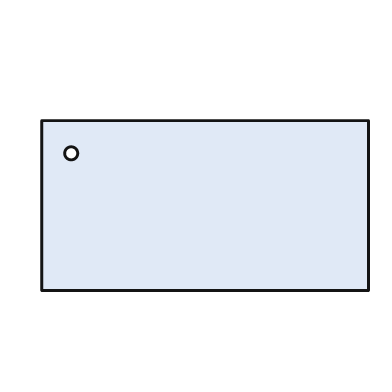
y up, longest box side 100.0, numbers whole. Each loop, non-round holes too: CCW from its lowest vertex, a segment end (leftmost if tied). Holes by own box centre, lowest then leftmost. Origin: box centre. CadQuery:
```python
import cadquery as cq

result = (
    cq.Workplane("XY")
    .moveTo(-50.0, -26.0)
    .lineTo(50.0, -26.0)
    .lineTo(50.0, 26.0)
    .lineTo(-50.0, 26.0)
    .close()
    .moveTo(-41.0, 16.0)
    .circle(2.0)
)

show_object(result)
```